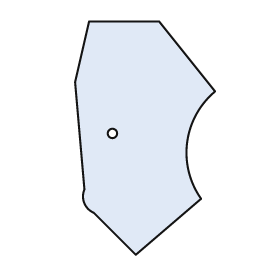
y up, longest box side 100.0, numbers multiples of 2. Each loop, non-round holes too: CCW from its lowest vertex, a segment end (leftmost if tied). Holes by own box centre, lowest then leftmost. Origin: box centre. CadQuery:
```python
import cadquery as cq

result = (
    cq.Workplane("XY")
    .moveTo(-4.0, -50.0)
    .lineTo(24.0, -26.0)
    .threePointArc((18.0, -2.0), (30.0, 20.0))
    .lineTo(6.0, 50.0)
    .lineTo(-24.0, 50.0)
    .lineTo(-30.0, 24.0)
    .lineTo(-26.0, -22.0)
    .threePointArc((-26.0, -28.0), (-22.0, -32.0))
    .close()
    .moveTo(-14.0, 2.0)
    .circle(2.0)
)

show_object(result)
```